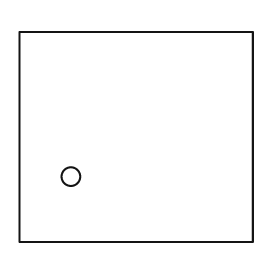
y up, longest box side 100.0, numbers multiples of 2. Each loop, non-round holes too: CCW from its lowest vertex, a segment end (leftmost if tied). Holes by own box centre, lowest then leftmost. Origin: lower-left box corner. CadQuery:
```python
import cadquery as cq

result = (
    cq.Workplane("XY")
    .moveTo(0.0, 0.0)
    .lineTo(100.0, 0.0)
    .lineTo(100.0, 90.0)
    .lineTo(0.0, 90.0)
    .close()
    .moveTo(22.0, 28.0)
    .circle(4.0)
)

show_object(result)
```